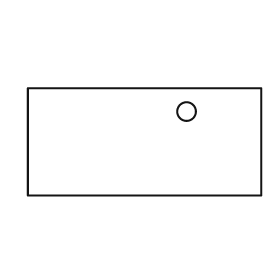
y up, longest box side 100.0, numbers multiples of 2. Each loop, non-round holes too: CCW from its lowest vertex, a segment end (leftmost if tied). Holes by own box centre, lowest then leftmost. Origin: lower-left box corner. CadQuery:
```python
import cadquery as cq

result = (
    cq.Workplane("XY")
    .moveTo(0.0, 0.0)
    .lineTo(100.0, 0.0)
    .lineTo(100.0, 46.0)
    .lineTo(0.0, 46.0)
    .close()
    .moveTo(68.0, 36.0)
    .circle(4.0)
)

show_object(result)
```